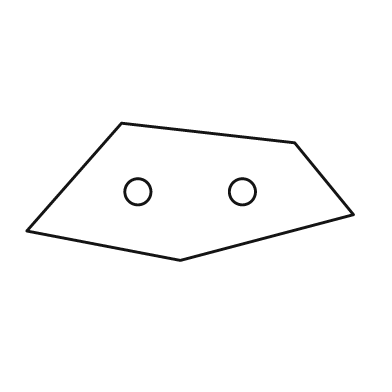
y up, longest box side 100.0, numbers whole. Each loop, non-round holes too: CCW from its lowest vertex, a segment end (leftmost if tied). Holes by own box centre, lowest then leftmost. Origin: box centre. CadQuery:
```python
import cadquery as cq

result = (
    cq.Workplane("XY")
    .moveTo(-3.0, -21.0)
    .lineTo(50.0, -7.0)
    .lineTo(32.0, 15.0)
    .lineTo(-21.0, 21.0)
    .lineTo(-50.0, -12.0)
    .close()
    .moveTo(-16.0, 0.0)
    .circle(4.0)
    .moveTo(16.0, 0.0)
    .circle(4.0)
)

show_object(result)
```